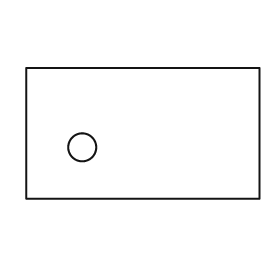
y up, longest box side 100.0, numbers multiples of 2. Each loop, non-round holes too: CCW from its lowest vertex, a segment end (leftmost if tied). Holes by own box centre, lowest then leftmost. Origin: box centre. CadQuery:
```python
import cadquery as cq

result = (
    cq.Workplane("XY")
    .moveTo(-50.0, -28.0)
    .lineTo(50.0, -28.0)
    .lineTo(50.0, 28.0)
    .lineTo(-50.0, 28.0)
    .close()
    .moveTo(-26.0, -6.0)
    .circle(6.0)
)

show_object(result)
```